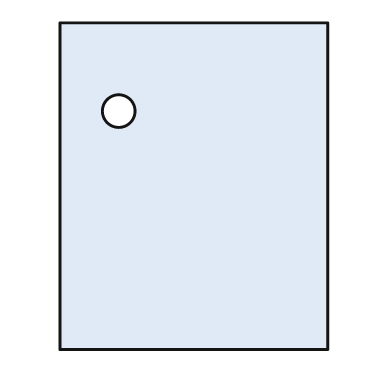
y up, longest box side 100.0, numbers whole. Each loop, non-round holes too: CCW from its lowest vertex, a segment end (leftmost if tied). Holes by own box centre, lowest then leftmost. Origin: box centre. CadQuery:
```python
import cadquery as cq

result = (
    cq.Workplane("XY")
    .moveTo(-41.0, -50.0)
    .lineTo(41.0, -50.0)
    .lineTo(41.0, 50.0)
    .lineTo(-41.0, 50.0)
    .close()
    .moveTo(-23.0, 23.0)
    .circle(5.0)
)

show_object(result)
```